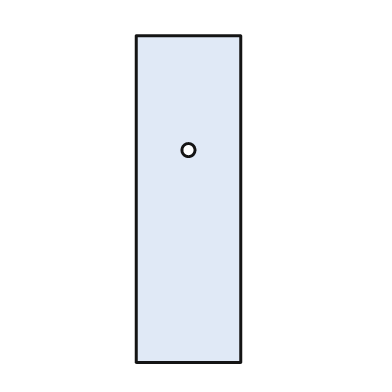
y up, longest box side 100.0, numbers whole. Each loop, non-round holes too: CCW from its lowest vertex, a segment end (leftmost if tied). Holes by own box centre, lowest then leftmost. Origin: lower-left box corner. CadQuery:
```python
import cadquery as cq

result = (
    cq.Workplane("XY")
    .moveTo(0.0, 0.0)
    .lineTo(32.0, 0.0)
    .lineTo(32.0, 100.0)
    .lineTo(0.0, 100.0)
    .close()
    .moveTo(16.0, 65.0)
    .circle(2.0)
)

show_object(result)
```